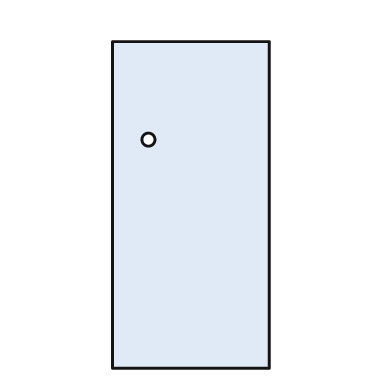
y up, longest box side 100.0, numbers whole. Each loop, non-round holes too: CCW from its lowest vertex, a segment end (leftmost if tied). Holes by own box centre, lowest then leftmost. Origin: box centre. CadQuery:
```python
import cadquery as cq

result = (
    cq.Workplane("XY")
    .moveTo(-24.0, -50.0)
    .lineTo(24.0, -50.0)
    .lineTo(24.0, 50.0)
    .lineTo(-24.0, 50.0)
    .close()
    .moveTo(-13.0, 20.0)
    .circle(2.0)
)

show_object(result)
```